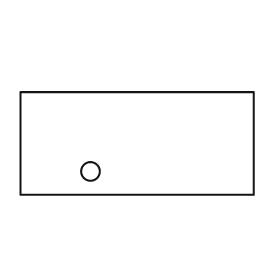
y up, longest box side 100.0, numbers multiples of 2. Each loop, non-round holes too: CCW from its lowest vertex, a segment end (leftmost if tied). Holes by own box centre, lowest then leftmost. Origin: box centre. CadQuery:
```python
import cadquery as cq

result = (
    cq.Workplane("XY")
    .moveTo(-50.0, -22.0)
    .lineTo(50.0, -22.0)
    .lineTo(50.0, 22.0)
    .lineTo(-50.0, 22.0)
    .close()
    .moveTo(-20.0, -12.0)
    .circle(4.0)
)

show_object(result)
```